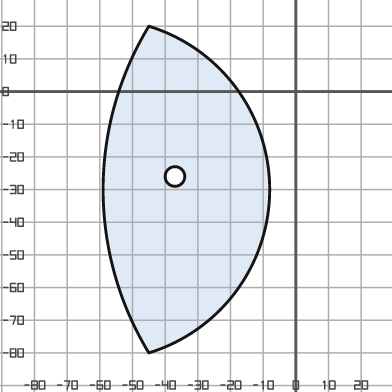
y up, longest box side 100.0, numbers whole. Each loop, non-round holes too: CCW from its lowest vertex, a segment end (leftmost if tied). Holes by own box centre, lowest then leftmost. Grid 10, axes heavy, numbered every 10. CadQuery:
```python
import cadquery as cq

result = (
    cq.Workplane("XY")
    .moveTo(-45.0, -80.0)
    .threePointArc((-8.0, -30.0), (-45.0, 20.0))
    .threePointArc((-59.0, -30.0), (-45.0, -80.0))
    .close()
    .moveTo(-37.0, -26.0)
    .circle(3.0)
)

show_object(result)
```